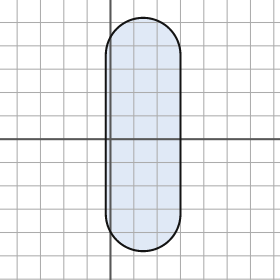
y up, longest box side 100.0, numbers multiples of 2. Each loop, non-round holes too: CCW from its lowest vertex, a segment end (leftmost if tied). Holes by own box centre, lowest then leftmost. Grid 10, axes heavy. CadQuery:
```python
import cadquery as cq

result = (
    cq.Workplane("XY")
    .moveTo(-2.0, -32.0)
    .threePointArc((14.0, -48.0), (30.0, -32.0))
    .lineTo(30.0, 36.0)
    .threePointArc((14.0, 52.0), (-2.0, 36.0))
    .close()
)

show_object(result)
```